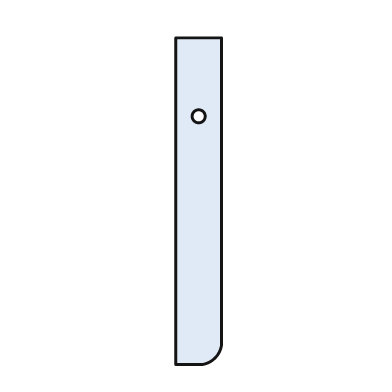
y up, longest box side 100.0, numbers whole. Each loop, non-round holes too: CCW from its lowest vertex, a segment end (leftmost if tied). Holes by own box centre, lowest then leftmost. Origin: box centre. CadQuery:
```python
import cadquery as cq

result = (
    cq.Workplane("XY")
    .moveTo(-7.0, -50.0)
    .lineTo(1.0, -50.0)
    .threePointArc((5.0, -48.0), (7.0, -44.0))
    .lineTo(7.0, 50.0)
    .lineTo(-7.0, 50.0)
    .close()
    .moveTo(0.0, 26.0)
    .circle(2.0)
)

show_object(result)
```